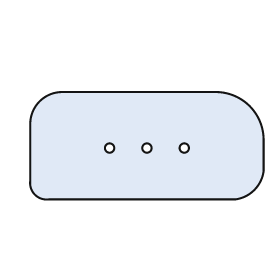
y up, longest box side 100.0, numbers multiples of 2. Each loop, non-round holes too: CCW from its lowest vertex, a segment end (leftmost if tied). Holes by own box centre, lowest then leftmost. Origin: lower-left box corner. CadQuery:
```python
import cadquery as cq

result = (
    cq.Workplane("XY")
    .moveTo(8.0, 0.0)
    .lineTo(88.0, 0.0)
    .threePointArc((96.0, 4.0), (100.0, 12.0))
    .lineTo(100.0, 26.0)
    .threePointArc((94.0, 40.0), (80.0, 46.0))
    .lineTo(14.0, 46.0)
    .threePointArc((4.0, 42.0), (0.0, 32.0))
    .lineTo(0.0, 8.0)
    .threePointArc((2.0, 2.0), (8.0, 0.0))
    .close()
    .moveTo(34.0, 22.0)
    .circle(2.0)
    .moveTo(50.0, 22.0)
    .circle(2.0)
    .moveTo(66.0, 22.0)
    .circle(2.0)
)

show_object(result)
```